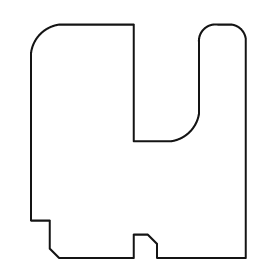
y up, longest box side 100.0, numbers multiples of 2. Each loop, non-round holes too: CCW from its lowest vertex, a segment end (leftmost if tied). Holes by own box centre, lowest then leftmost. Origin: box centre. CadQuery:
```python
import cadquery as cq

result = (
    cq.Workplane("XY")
    .moveTo(-34.0, -50.0)
    .lineTo(-2.0, -50.0)
    .lineTo(-2.0, -40.0)
    .lineTo(4.0, -40.0)
    .lineTo(8.0, -44.0)
    .lineTo(8.0, -50.0)
    .lineTo(46.0, -50.0)
    .lineTo(46.0, 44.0)
    .threePointArc((44.0, 48.0), (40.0, 50.0))
    .lineTo(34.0, 50.0)
    .threePointArc((28.0, 48.0), (26.0, 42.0))
    .lineTo(26.0, 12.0)
    .threePointArc((22.0, 4.0), (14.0, 0.0))
    .lineTo(-2.0, 0.0)
    .lineTo(-2.0, 50.0)
    .lineTo(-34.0, 50.0)
    .threePointArc((-42.0, 46.0), (-46.0, 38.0))
    .lineTo(-46.0, -34.0)
    .lineTo(-38.0, -34.0)
    .lineTo(-38.0, -46.0)
    .close()
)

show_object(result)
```